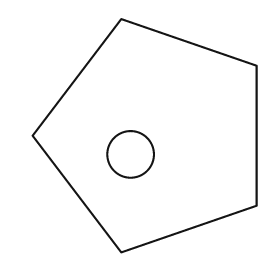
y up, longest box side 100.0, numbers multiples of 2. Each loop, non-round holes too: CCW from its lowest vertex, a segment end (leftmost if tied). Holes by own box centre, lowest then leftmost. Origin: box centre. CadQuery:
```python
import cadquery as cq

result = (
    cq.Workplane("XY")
    .moveTo(-10.0, -50.0)
    .lineTo(48.0, -30.0)
    .lineTo(48.0, 30.0)
    .lineTo(-10.0, 50.0)
    .lineTo(-48.0, 0.0)
    .close()
    .moveTo(-6.0, -8.0)
    .circle(10.0)
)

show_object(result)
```